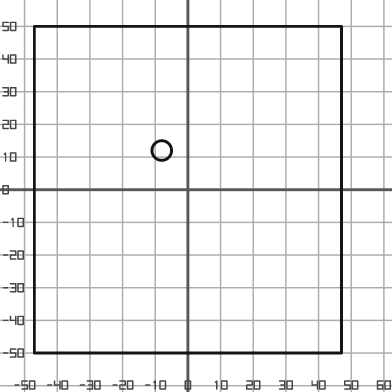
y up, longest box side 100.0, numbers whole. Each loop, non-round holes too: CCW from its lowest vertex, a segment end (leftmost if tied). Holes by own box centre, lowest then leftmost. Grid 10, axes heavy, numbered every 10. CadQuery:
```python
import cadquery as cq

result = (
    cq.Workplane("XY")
    .moveTo(-47.0, -50.0)
    .lineTo(47.0, -50.0)
    .lineTo(47.0, 50.0)
    .lineTo(-47.0, 50.0)
    .close()
    .moveTo(-8.0, 12.0)
    .circle(3.0)
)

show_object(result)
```